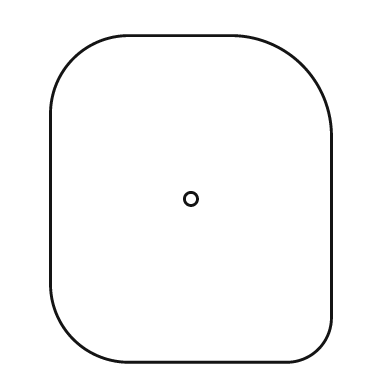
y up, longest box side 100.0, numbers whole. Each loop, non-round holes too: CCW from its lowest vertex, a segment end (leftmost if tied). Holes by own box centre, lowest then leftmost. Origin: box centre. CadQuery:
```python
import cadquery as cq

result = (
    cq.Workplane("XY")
    .moveTo(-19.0, -50.0)
    .lineTo(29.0, -50.0)
    .threePointArc((39.0, -46.0), (43.0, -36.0))
    .lineTo(43.0, 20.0)
    .threePointArc((34.0, 41.0), (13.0, 50.0))
    .lineTo(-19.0, 50.0)
    .threePointArc((-36.0, 43.0), (-43.0, 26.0))
    .lineTo(-43.0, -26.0)
    .threePointArc((-36.0, -43.0), (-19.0, -50.0))
    .close()
    .moveTo(0.0, 0.0)
    .circle(2.0)
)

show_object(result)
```